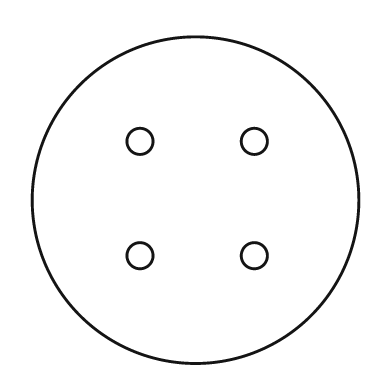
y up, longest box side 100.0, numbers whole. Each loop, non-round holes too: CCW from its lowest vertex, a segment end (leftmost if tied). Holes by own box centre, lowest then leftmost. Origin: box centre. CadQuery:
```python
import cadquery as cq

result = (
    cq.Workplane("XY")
    .moveTo(0.0, 0.0)
    .circle(50.0)
    .moveTo(-17.0, -17.0)
    .circle(4.0)
    .moveTo(18.0, -17.0)
    .circle(4.0)
    .moveTo(-17.0, 18.0)
    .circle(4.0)
    .moveTo(18.0, 18.0)
    .circle(4.0)
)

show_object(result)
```